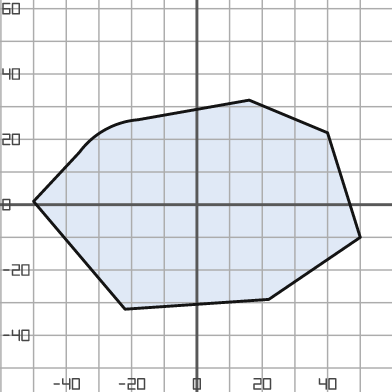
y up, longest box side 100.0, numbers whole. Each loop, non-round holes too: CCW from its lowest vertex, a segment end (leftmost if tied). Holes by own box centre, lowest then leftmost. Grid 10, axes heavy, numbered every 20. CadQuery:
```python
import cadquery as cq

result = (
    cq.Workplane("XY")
    .moveTo(-22.0, -32.0)
    .lineTo(22.0, -29.0)
    .lineTo(50.0, -10.0)
    .lineTo(40.0, 22.0)
    .lineTo(16.0, 32.0)
    .lineTo(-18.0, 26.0)
    .threePointArc((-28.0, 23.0), (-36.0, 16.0))
    .lineTo(-50.0, 1.0)
    .close()
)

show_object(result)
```